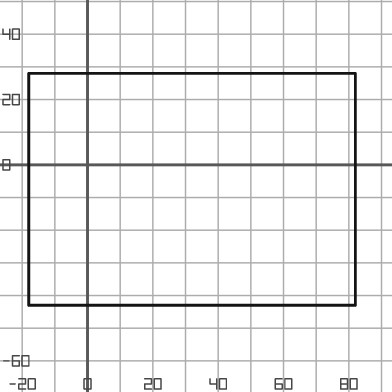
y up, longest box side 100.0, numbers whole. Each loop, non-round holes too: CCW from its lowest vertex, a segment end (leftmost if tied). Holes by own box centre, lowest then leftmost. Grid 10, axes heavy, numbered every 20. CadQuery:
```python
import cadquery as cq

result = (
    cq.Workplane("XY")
    .moveTo(-18.0, -43.0)
    .lineTo(82.0, -43.0)
    .lineTo(82.0, 28.0)
    .lineTo(-18.0, 28.0)
    .close()
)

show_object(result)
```